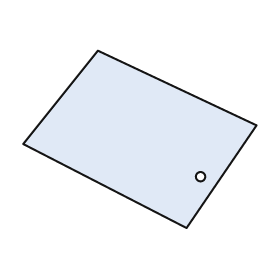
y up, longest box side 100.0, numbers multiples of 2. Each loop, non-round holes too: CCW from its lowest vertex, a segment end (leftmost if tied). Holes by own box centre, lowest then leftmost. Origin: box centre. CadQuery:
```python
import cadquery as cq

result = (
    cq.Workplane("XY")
    .moveTo(20.0, -38.0)
    .lineTo(50.0, 6.0)
    .lineTo(-18.0, 38.0)
    .lineTo(-50.0, -2.0)
    .close()
    .moveTo(26.0, -16.0)
    .circle(2.0)
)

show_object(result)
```